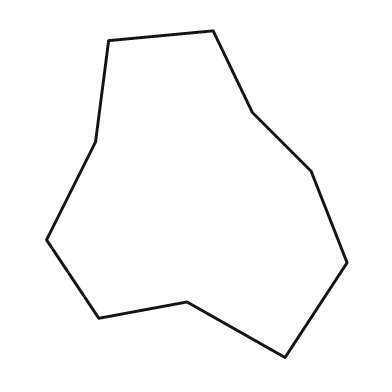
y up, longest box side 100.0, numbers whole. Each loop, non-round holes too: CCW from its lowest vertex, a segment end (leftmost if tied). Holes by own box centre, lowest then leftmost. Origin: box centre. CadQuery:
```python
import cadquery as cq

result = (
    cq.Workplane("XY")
    .moveTo(27.0, -50.0)
    .lineTo(46.0, -21.0)
    .lineTo(35.0, 7.0)
    .lineTo(17.0, 25.0)
    .lineTo(5.0, 50.0)
    .lineTo(-27.0, 47.0)
    .lineTo(-31.0, 16.0)
    .lineTo(-46.0, -14.0)
    .lineTo(-30.0, -38.0)
    .lineTo(-3.0, -33.0)
    .close()
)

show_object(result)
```